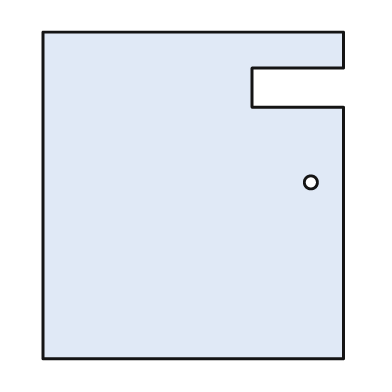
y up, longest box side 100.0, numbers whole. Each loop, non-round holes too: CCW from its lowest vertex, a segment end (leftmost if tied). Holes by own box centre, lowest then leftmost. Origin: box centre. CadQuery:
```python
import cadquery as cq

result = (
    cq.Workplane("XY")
    .moveTo(-46.0, -50.0)
    .lineTo(46.0, -50.0)
    .lineTo(46.0, 27.0)
    .lineTo(18.0, 27.0)
    .lineTo(18.0, 39.0)
    .lineTo(46.0, 39.0)
    .lineTo(46.0, 50.0)
    .lineTo(-46.0, 50.0)
    .close()
    .moveTo(36.0, 4.0)
    .circle(2.0)
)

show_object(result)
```